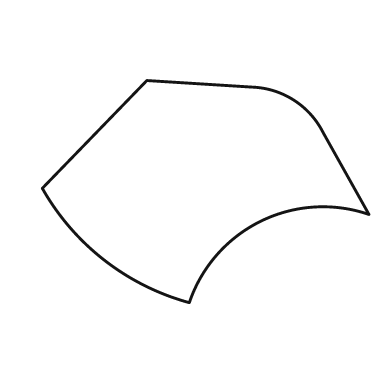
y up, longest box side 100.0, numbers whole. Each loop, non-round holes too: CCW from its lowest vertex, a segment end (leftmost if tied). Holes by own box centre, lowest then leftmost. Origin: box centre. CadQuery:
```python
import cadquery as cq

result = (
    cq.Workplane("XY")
    .moveTo(-5.0, -34.0)
    .threePointArc((17.0, -9.0), (50.0, -7.0))
    .lineTo(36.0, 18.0)
    .threePointArc((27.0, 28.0), (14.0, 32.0))
    .lineTo(-18.0, 34.0)
    .lineTo(-50.0, 1.0)
    .threePointArc((-31.0, -21.0), (-5.0, -34.0))
    .close()
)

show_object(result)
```